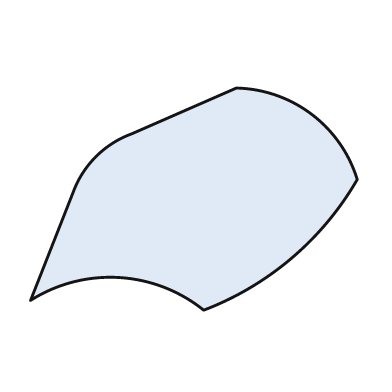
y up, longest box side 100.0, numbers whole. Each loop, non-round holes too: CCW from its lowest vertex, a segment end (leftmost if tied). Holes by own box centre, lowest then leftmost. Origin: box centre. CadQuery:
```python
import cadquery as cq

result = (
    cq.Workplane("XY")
    .moveTo(3.0, -34.0)
    .threePointArc((30.0, -18.0), (50.0, 6.0))
    .threePointArc((36.0, 26.0), (13.0, 34.0))
    .lineTo(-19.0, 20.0)
    .threePointArc((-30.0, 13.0), (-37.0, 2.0))
    .lineTo(-50.0, -31.0)
    .threePointArc((-23.0, -24.0), (3.0, -34.0))
    .close()
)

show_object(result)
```